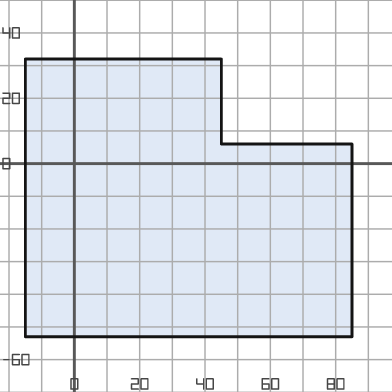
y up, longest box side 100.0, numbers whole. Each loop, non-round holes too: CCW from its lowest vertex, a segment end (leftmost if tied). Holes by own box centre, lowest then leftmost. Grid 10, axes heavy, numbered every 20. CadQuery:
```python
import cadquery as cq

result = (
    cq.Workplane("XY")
    .moveTo(-15.0, -53.0)
    .lineTo(85.0, -53.0)
    .lineTo(85.0, 6.0)
    .lineTo(45.0, 6.0)
    .lineTo(45.0, 32.0)
    .lineTo(-15.0, 32.0)
    .close()
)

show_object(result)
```